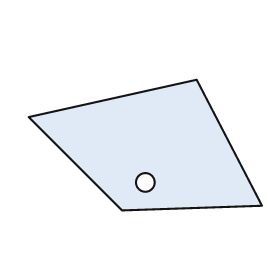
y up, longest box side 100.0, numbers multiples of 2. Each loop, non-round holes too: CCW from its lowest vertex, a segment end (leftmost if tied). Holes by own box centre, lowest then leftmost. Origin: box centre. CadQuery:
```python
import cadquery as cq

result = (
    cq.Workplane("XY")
    .moveTo(-10.0, -28.0)
    .lineTo(50.0, -26.0)
    .lineTo(22.0, 28.0)
    .lineTo(-50.0, 12.0)
    .close()
    .moveTo(0.0, -16.0)
    .circle(4.0)
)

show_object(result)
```